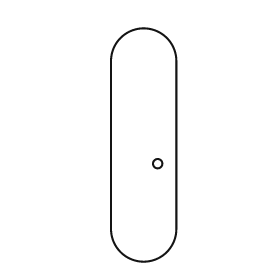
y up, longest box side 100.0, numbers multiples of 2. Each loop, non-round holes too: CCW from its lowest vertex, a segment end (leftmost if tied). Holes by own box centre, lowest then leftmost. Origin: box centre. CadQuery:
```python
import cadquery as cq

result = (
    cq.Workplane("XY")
    .moveTo(-14.0, -36.0)
    .threePointArc((0.0, -50.0), (14.0, -36.0))
    .lineTo(14.0, 36.0)
    .threePointArc((0.0, 50.0), (-14.0, 36.0))
    .close()
    .moveTo(6.0, -8.0)
    .circle(2.0)
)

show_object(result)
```